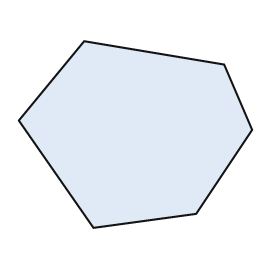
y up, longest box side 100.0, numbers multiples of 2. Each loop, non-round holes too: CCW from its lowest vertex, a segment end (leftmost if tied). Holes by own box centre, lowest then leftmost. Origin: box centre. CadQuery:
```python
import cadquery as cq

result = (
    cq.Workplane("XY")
    .moveTo(-18.0, -40.0)
    .lineTo(26.0, -34.0)
    .lineTo(50.0, 2.0)
    .lineTo(38.0, 30.0)
    .lineTo(-22.0, 40.0)
    .lineTo(-50.0, 6.0)
    .close()
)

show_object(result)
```